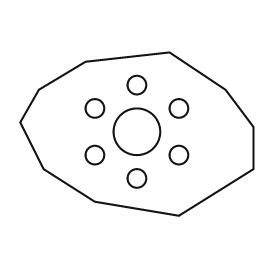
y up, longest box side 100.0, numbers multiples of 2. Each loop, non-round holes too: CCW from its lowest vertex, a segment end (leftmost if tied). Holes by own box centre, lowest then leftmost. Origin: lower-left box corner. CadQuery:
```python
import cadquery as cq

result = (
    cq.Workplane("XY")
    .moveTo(68.0, 0.0)
    .lineTo(100.0, 20.0)
    .lineTo(100.0, 38.0)
    .lineTo(88.0, 54.0)
    .lineTo(64.0, 70.0)
    .lineTo(28.0, 66.0)
    .lineTo(8.0, 54.0)
    .lineTo(0.0, 40.0)
    .lineTo(10.0, 20.0)
    .lineTo(32.0, 6.0)
    .close()
    .moveTo(50.0, 16.0)
    .circle(4.0)
    .moveTo(32.0, 26.0)
    .circle(4.0)
    .moveTo(68.0, 26.0)
    .circle(4.0)
    .moveTo(50.0, 36.0)
    .circle(10.0)
    .moveTo(32.0, 46.0)
    .circle(4.0)
    .moveTo(68.0, 46.0)
    .circle(4.0)
    .moveTo(50.0, 56.0)
    .circle(4.0)
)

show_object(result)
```